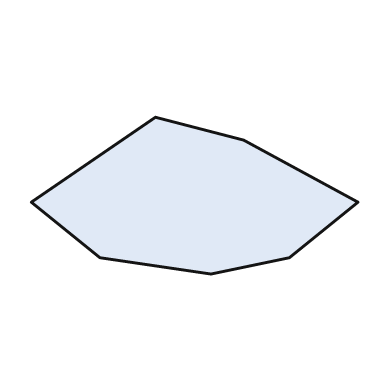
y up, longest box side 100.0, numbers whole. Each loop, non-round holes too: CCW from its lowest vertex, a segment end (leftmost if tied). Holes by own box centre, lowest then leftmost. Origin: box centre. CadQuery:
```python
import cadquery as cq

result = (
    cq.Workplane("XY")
    .moveTo(5.0, -24.0)
    .lineTo(29.0, -19.0)
    .lineTo(50.0, -2.0)
    .lineTo(15.0, 17.0)
    .lineTo(-12.0, 24.0)
    .lineTo(-50.0, -2.0)
    .lineTo(-29.0, -19.0)
    .close()
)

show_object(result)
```